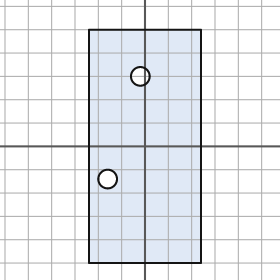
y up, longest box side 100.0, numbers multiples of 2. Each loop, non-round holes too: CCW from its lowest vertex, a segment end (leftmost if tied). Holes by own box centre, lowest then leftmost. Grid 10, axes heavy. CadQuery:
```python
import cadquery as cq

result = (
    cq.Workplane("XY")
    .moveTo(-24.0, -50.0)
    .lineTo(24.0, -50.0)
    .lineTo(24.0, 50.0)
    .lineTo(-24.0, 50.0)
    .close()
    .moveTo(-16.0, -14.0)
    .circle(4.0)
    .moveTo(-2.0, 30.0)
    .circle(4.0)
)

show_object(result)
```